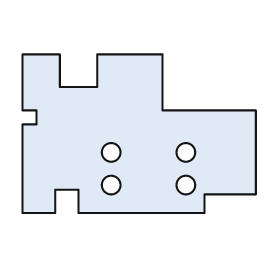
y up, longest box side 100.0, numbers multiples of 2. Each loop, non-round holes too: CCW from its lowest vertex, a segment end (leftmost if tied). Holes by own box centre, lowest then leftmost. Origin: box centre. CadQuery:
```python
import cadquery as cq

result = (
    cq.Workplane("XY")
    .moveTo(-50.0, -34.0)
    .lineTo(-36.0, -34.0)
    .lineTo(-36.0, -24.0)
    .lineTo(-26.0, -24.0)
    .lineTo(-26.0, -34.0)
    .lineTo(28.0, -34.0)
    .lineTo(28.0, -26.0)
    .lineTo(50.0, -26.0)
    .lineTo(50.0, 10.0)
    .lineTo(10.0, 10.0)
    .lineTo(10.0, 34.0)
    .lineTo(-18.0, 34.0)
    .lineTo(-18.0, 20.0)
    .lineTo(-34.0, 20.0)
    .lineTo(-34.0, 34.0)
    .lineTo(-50.0, 34.0)
    .lineTo(-50.0, 10.0)
    .lineTo(-44.0, 10.0)
    .lineTo(-44.0, 4.0)
    .lineTo(-50.0, 4.0)
    .close()
    .moveTo(-12.0, -22.0)
    .circle(4.0)
    .moveTo(20.0, -22.0)
    .circle(4.0)
    .moveTo(-12.0, -8.0)
    .circle(4.0)
    .moveTo(20.0, -8.0)
    .circle(4.0)
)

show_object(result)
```